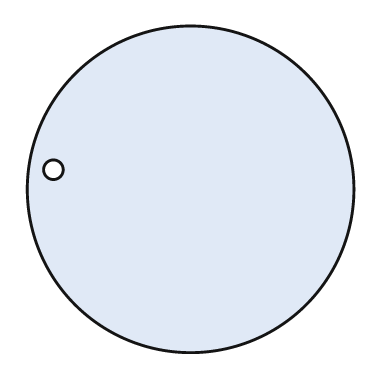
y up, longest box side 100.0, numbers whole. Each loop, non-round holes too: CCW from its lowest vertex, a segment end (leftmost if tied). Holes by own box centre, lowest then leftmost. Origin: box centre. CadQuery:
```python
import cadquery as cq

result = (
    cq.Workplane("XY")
    .moveTo(0.0, 0.0)
    .circle(50.0)
    .moveTo(-42.0, 6.0)
    .circle(3.0)
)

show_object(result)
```